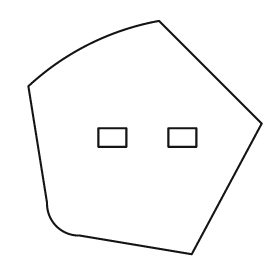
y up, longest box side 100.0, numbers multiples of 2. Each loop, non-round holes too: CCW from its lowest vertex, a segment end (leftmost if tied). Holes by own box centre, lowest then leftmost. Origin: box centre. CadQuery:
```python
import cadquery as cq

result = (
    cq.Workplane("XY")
    .moveTo(20.0, -50.0)
    .lineTo(50.0, 6.0)
    .lineTo(6.0, 50.0)
    .threePointArc((-24.0, 40.0), (-50.0, 22.0))
    .lineTo(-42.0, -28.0)
    .threePointArc((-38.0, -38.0), (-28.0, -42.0))
    .close()
    .moveTo(-20.0, -4.0)
    .lineTo(-8.0, -4.0)
    .lineTo(-8.0, 4.0)
    .lineTo(-20.0, 4.0)
    .close()
    .moveTo(10.0, -4.0)
    .lineTo(22.0, -4.0)
    .lineTo(22.0, 4.0)
    .lineTo(10.0, 4.0)
    .close()
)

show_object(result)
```